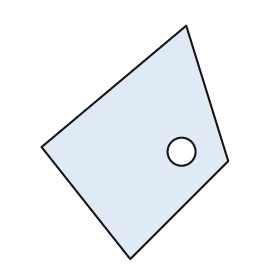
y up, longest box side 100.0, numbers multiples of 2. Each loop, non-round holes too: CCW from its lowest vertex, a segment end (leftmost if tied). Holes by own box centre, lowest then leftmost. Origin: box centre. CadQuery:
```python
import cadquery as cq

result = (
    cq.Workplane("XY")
    .moveTo(-2.0, -50.0)
    .lineTo(40.0, -8.0)
    .lineTo(22.0, 50.0)
    .lineTo(-40.0, -2.0)
    .close()
    .moveTo(20.0, -4.0)
    .circle(6.0)
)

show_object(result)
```